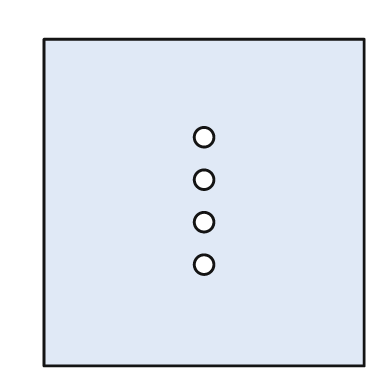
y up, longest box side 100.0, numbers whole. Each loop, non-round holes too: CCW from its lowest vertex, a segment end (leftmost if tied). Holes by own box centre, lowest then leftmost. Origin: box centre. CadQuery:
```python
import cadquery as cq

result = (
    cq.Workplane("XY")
    .moveTo(-49.0, -50.0)
    .lineTo(49.0, -50.0)
    .lineTo(49.0, 50.0)
    .lineTo(-49.0, 50.0)
    .close()
    .moveTo(0.0, -19.0)
    .circle(3.0)
    .moveTo(0.0, -6.0)
    .circle(3.0)
    .moveTo(0.0, 7.0)
    .circle(3.0)
    .moveTo(0.0, 20.0)
    .circle(3.0)
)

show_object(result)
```